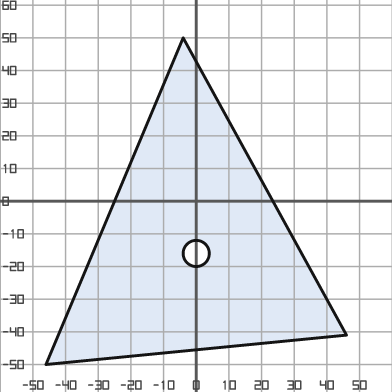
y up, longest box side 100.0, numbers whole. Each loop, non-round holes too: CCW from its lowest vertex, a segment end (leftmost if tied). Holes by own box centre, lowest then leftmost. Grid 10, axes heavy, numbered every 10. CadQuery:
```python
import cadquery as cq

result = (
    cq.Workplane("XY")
    .moveTo(-46.0, -50.0)
    .lineTo(46.0, -41.0)
    .lineTo(-4.0, 50.0)
    .close()
    .moveTo(0.0, -16.0)
    .circle(4.0)
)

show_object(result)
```